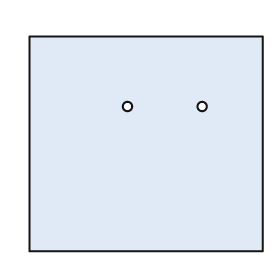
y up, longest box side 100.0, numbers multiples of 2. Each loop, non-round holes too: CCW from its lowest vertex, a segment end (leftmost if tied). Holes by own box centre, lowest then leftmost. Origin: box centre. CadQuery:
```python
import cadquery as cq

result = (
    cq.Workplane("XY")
    .moveTo(-50.0, -46.0)
    .lineTo(50.0, -46.0)
    .lineTo(50.0, 46.0)
    .lineTo(-50.0, 46.0)
    .close()
    .moveTo(-8.0, 16.0)
    .circle(2.0)
    .moveTo(24.0, 16.0)
    .circle(2.0)
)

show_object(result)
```